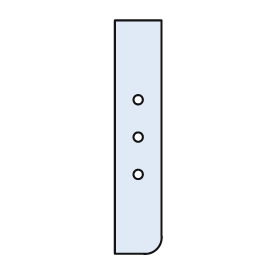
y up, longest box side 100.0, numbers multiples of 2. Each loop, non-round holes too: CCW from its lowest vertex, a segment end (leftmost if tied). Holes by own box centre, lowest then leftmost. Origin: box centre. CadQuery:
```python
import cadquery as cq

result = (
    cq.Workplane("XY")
    .moveTo(-10.0, -50.0)
    .lineTo(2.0, -50.0)
    .threePointArc((8.0, -48.0), (10.0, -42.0))
    .lineTo(10.0, 50.0)
    .lineTo(-10.0, 50.0)
    .close()
    .moveTo(0.0, -16.0)
    .circle(2.0)
    .moveTo(0.0, 0.0)
    .circle(2.0)
    .moveTo(0.0, 16.0)
    .circle(2.0)
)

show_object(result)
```